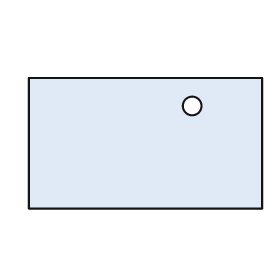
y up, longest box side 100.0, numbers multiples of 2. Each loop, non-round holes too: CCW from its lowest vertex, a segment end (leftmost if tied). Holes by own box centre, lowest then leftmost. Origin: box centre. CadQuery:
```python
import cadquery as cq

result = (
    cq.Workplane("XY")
    .moveTo(-50.0, -28.0)
    .lineTo(50.0, -28.0)
    .lineTo(50.0, 28.0)
    .lineTo(-50.0, 28.0)
    .close()
    .moveTo(20.0, 16.0)
    .circle(4.0)
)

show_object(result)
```